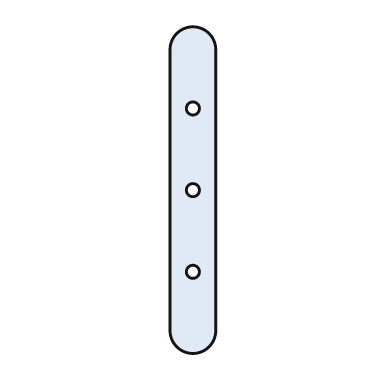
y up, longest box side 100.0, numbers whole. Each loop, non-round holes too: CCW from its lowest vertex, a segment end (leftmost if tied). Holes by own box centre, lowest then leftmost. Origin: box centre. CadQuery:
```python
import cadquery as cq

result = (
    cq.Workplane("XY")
    .moveTo(-7.0, -43.0)
    .threePointArc((0.0, -50.0), (7.0, -43.0))
    .lineTo(7.0, 43.0)
    .threePointArc((0.0, 50.0), (-7.0, 43.0))
    .close()
    .moveTo(0.0, -25.0)
    .circle(2.0)
    .moveTo(0.0, 0.0)
    .circle(2.0)
    .moveTo(0.0, 25.0)
    .circle(2.0)
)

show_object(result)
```